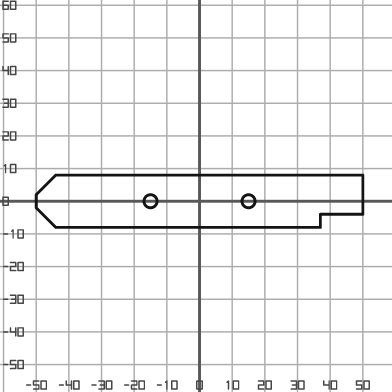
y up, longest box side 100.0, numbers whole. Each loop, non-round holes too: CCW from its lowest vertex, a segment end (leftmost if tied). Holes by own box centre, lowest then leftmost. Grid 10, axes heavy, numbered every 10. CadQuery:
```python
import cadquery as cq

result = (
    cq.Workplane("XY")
    .moveTo(-44.0, -8.0)
    .lineTo(37.0, -8.0)
    .lineTo(37.0, -4.0)
    .lineTo(50.0, -4.0)
    .lineTo(50.0, 8.0)
    .lineTo(-44.0, 8.0)
    .lineTo(-50.0, 2.0)
    .lineTo(-50.0, -2.0)
    .close()
    .moveTo(-15.0, 0.0)
    .circle(2.0)
    .moveTo(15.0, 0.0)
    .circle(2.0)
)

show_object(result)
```